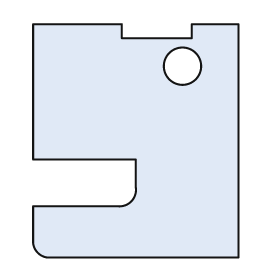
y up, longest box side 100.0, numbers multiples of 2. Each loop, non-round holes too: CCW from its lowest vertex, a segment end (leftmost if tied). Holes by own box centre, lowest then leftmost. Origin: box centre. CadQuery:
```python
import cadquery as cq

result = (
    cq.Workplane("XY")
    .moveTo(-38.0, -50.0)
    .lineTo(44.0, -50.0)
    .lineTo(44.0, 50.0)
    .lineTo(24.0, 50.0)
    .lineTo(24.0, 44.0)
    .lineTo(-6.0, 44.0)
    .lineTo(-6.0, 50.0)
    .lineTo(-44.0, 50.0)
    .lineTo(-44.0, -8.0)
    .lineTo(0.0, -8.0)
    .lineTo(0.0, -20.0)
    .threePointArc((-2.0, -26.0), (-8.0, -28.0))
    .lineTo(-44.0, -28.0)
    .lineTo(-44.0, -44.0)
    .threePointArc((-42.0, -48.0), (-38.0, -50.0))
    .close()
    .moveTo(20.0, 32.0)
    .circle(8.0)
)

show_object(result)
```